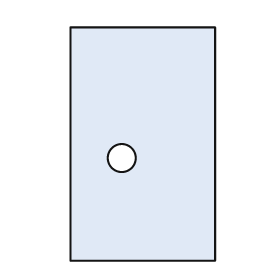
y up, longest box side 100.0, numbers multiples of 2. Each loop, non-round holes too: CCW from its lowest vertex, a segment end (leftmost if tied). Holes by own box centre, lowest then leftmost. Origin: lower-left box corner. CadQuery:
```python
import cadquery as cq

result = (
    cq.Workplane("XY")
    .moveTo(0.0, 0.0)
    .lineTo(62.0, 0.0)
    .lineTo(62.0, 100.0)
    .lineTo(0.0, 100.0)
    .close()
    .moveTo(22.0, 44.0)
    .circle(6.0)
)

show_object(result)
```